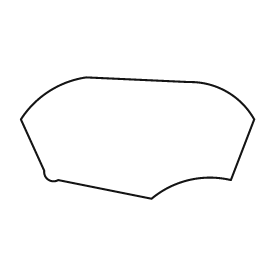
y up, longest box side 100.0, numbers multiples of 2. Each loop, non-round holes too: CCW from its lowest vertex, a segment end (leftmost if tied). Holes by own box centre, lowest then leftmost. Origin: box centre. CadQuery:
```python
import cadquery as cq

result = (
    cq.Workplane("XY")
    .moveTo(6.0, -26.0)
    .threePointArc((22.0, -18.0), (40.0, -18.0))
    .lineTo(50.0, 8.0)
    .threePointArc((38.0, 20.0), (22.0, 24.0))
    .lineTo(-22.0, 26.0)
    .threePointArc((-38.0, 20.0), (-50.0, 8.0))
    .lineTo(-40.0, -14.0)
    .threePointArc((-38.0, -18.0), (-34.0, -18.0))
    .close()
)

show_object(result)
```